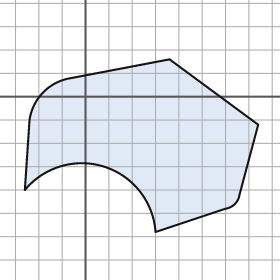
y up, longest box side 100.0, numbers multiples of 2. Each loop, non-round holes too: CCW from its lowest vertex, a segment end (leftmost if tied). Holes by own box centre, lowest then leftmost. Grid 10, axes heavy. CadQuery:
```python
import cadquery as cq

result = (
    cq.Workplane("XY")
    .moveTo(30.0, -58.0)
    .lineTo(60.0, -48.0)
    .threePointArc((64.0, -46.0), (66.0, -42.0))
    .lineTo(74.0, -12.0)
    .lineTo(36.0, 16.0)
    .lineTo(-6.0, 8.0)
    .threePointArc((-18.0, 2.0), (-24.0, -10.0))
    .lineTo(-26.0, -40.0)
    .threePointArc((8.0, -30.0), (30.0, -58.0))
    .close()
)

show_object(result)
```